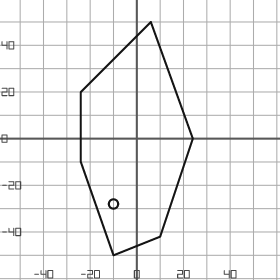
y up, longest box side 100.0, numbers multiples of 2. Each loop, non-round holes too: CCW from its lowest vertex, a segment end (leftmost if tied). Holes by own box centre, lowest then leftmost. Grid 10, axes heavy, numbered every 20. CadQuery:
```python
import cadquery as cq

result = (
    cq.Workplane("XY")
    .moveTo(-10.0, -50.0)
    .lineTo(10.0, -42.0)
    .lineTo(24.0, 0.0)
    .lineTo(6.0, 50.0)
    .lineTo(-24.0, 20.0)
    .lineTo(-24.0, -10.0)
    .close()
    .moveTo(-10.0, -28.0)
    .circle(2.0)
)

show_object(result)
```